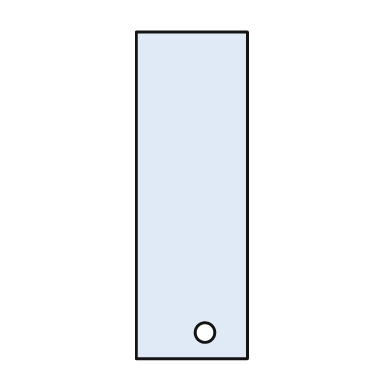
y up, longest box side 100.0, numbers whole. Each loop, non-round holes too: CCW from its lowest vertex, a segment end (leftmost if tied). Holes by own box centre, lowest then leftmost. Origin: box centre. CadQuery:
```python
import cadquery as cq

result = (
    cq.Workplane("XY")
    .moveTo(-17.0, -50.0)
    .lineTo(17.0, -50.0)
    .lineTo(17.0, 50.0)
    .lineTo(-17.0, 50.0)
    .close()
    .moveTo(4.0, -42.0)
    .circle(3.0)
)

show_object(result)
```